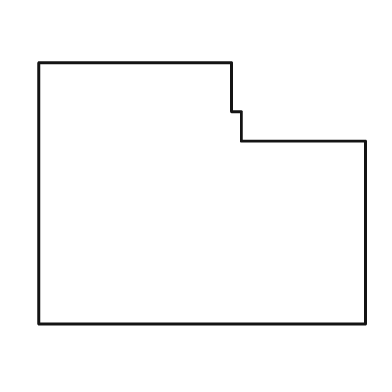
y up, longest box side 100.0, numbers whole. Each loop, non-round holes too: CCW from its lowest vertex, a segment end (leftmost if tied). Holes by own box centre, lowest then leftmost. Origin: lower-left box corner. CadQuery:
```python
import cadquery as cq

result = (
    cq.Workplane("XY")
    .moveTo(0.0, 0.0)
    .lineTo(100.0, 0.0)
    .lineTo(100.0, 56.0)
    .lineTo(62.0, 56.0)
    .lineTo(62.0, 65.0)
    .lineTo(59.0, 65.0)
    .lineTo(59.0, 80.0)
    .lineTo(0.0, 80.0)
    .close()
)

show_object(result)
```